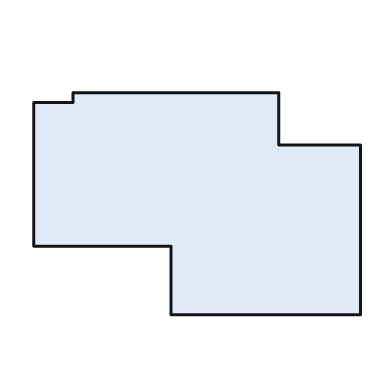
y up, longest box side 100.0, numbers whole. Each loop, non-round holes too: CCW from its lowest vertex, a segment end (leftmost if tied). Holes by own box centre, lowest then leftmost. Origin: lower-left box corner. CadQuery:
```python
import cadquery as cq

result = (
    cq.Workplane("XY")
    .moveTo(42.0, 0.0)
    .lineTo(100.0, 0.0)
    .lineTo(100.0, 52.0)
    .lineTo(75.0, 52.0)
    .lineTo(75.0, 68.0)
    .lineTo(12.0, 68.0)
    .lineTo(12.0, 65.0)
    .lineTo(0.0, 65.0)
    .lineTo(0.0, 21.0)
    .lineTo(42.0, 21.0)
    .close()
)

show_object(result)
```